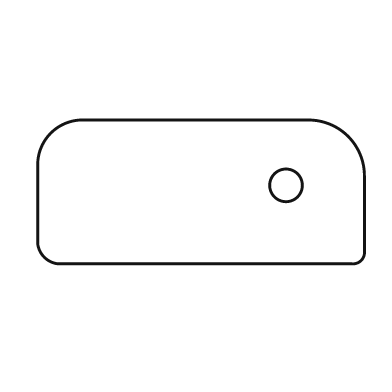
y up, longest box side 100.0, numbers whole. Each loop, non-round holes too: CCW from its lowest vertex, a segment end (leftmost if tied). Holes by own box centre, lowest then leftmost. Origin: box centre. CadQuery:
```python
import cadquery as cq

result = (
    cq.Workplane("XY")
    .moveTo(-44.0, -22.0)
    .lineTo(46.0, -22.0)
    .threePointArc((49.0, -21.0), (50.0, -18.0))
    .lineTo(50.0, 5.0)
    .threePointArc((45.0, 17.0), (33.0, 22.0))
    .lineTo(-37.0, 22.0)
    .threePointArc((-46.0, 18.0), (-50.0, 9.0))
    .lineTo(-50.0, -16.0)
    .threePointArc((-48.0, -20.0), (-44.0, -22.0))
    .close()
    .moveTo(26.0, 2.0)
    .circle(5.0)
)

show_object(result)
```